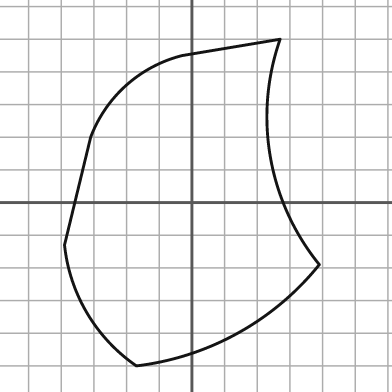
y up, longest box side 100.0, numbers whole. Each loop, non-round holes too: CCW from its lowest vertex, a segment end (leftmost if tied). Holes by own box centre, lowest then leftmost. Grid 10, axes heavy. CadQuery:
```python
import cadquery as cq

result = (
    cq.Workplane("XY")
    .moveTo(-17.0, -50.0)
    .threePointArc((14.0, -40.0), (39.0, -19.0))
    .threePointArc((24.0, 14.0), (27.0, 50.0))
    .lineTo(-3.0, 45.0)
    .threePointArc((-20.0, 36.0), (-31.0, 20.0))
    .lineTo(-39.0, -13.0)
    .threePointArc((-32.0, -34.0), (-17.0, -50.0))
    .close()
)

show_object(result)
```